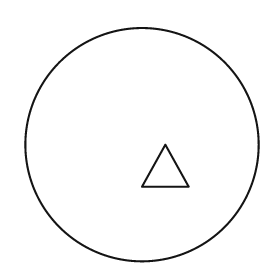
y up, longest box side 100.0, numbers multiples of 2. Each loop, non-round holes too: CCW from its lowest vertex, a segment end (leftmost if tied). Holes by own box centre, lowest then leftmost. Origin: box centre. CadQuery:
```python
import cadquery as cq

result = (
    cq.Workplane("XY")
    .moveTo(0.0, 0.0)
    .circle(50.0)
    .moveTo(0.0, -18.0)
    .lineTo(20.0, -18.0)
    .lineTo(10.0, 0.0)
    .close()
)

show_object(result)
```